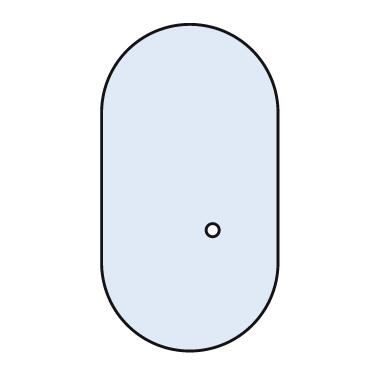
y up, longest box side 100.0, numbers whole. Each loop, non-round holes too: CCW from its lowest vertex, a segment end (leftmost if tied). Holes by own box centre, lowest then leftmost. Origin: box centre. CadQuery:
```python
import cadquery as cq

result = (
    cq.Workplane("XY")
    .moveTo(-27.0, -23.0)
    .threePointArc((0.0, -50.0), (27.0, -23.0))
    .lineTo(27.0, 23.0)
    .threePointArc((0.0, 50.0), (-27.0, 23.0))
    .close()
    .moveTo(7.0, -13.0)
    .circle(2.0)
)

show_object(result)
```